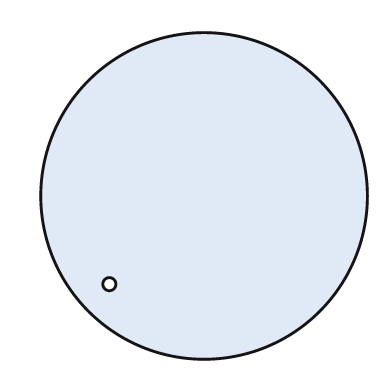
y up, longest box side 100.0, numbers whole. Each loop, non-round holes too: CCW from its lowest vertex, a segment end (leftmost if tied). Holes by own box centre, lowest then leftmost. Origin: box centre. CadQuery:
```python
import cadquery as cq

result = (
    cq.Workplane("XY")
    .moveTo(0.0, 0.0)
    .circle(50.0)
    .moveTo(-29.0, -27.0)
    .circle(2.0)
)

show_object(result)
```